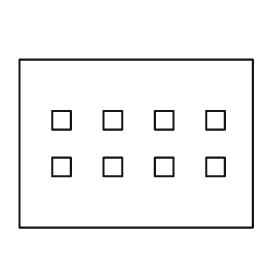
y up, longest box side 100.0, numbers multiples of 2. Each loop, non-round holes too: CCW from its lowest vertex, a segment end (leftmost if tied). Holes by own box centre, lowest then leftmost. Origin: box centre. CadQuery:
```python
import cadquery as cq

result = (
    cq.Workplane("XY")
    .moveTo(-50.0, -36.0)
    .lineTo(50.0, -36.0)
    .lineTo(50.0, 36.0)
    .lineTo(-50.0, 36.0)
    .close()
    .moveTo(-36.0, -14.0)
    .lineTo(-28.0, -14.0)
    .lineTo(-28.0, -6.0)
    .lineTo(-36.0, -6.0)
    .close()
    .moveTo(-14.0, -14.0)
    .lineTo(-6.0, -14.0)
    .lineTo(-6.0, -6.0)
    .lineTo(-14.0, -6.0)
    .close()
    .moveTo(8.0, -14.0)
    .lineTo(16.0, -14.0)
    .lineTo(16.0, -6.0)
    .lineTo(8.0, -6.0)
    .close()
    .moveTo(30.0, -14.0)
    .lineTo(38.0, -14.0)
    .lineTo(38.0, -6.0)
    .lineTo(30.0, -6.0)
    .close()
    .moveTo(-36.0, 6.0)
    .lineTo(-28.0, 6.0)
    .lineTo(-28.0, 14.0)
    .lineTo(-36.0, 14.0)
    .close()
    .moveTo(-14.0, 6.0)
    .lineTo(-6.0, 6.0)
    .lineTo(-6.0, 14.0)
    .lineTo(-14.0, 14.0)
    .close()
    .moveTo(8.0, 6.0)
    .lineTo(16.0, 6.0)
    .lineTo(16.0, 14.0)
    .lineTo(8.0, 14.0)
    .close()
    .moveTo(30.0, 6.0)
    .lineTo(38.0, 6.0)
    .lineTo(38.0, 14.0)
    .lineTo(30.0, 14.0)
    .close()
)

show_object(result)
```